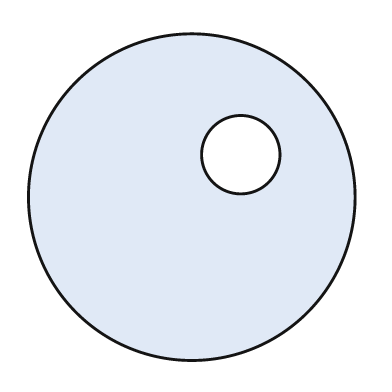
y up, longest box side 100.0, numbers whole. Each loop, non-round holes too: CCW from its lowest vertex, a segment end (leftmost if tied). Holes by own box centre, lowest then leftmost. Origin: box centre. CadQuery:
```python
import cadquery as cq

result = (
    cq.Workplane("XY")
    .moveTo(0.0, 0.0)
    .circle(50.0)
    .moveTo(15.0, 13.0)
    .circle(12.0)
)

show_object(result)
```